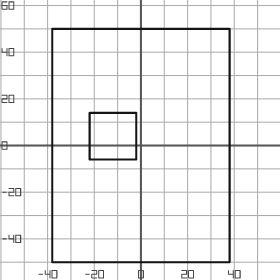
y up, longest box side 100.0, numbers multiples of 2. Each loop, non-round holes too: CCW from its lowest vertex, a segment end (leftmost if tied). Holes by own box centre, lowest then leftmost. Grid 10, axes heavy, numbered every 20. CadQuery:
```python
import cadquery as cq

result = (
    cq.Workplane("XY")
    .moveTo(-38.0, -50.0)
    .lineTo(38.0, -50.0)
    .lineTo(38.0, 50.0)
    .lineTo(-38.0, 50.0)
    .close()
    .moveTo(-22.0, -6.0)
    .lineTo(-2.0, -6.0)
    .lineTo(-2.0, 14.0)
    .lineTo(-22.0, 14.0)
    .close()
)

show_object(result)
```